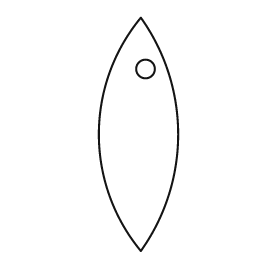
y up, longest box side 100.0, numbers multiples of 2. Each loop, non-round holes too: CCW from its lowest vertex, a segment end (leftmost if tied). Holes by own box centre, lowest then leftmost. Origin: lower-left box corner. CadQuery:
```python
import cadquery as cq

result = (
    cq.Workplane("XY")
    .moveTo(18.0, 0.0)
    .threePointArc((34.0, 50.0), (18.0, 100.0))
    .threePointArc((0.0, 50.0), (18.0, 0.0))
    .close()
    .moveTo(20.0, 78.0)
    .circle(4.0)
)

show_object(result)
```